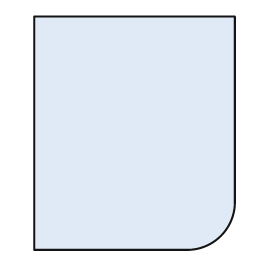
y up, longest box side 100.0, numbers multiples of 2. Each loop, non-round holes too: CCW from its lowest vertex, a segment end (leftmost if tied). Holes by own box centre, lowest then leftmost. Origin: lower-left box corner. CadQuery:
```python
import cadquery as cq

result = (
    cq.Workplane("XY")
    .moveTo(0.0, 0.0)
    .lineTo(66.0, 0.0)
    .threePointArc((80.0, 6.0), (86.0, 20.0))
    .lineTo(86.0, 100.0)
    .lineTo(0.0, 100.0)
    .close()
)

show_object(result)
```